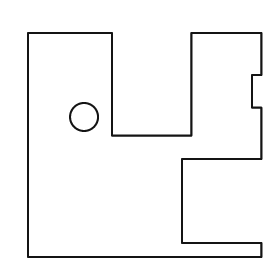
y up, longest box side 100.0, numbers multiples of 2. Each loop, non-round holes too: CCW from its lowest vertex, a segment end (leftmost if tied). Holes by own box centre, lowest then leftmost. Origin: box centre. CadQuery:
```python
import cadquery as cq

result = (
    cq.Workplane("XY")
    .moveTo(-50.0, -48.0)
    .lineTo(50.0, -48.0)
    .lineTo(50.0, -42.0)
    .lineTo(16.0, -42.0)
    .lineTo(16.0, -6.0)
    .lineTo(50.0, -6.0)
    .lineTo(50.0, 16.0)
    .lineTo(46.0, 16.0)
    .lineTo(46.0, 30.0)
    .lineTo(50.0, 30.0)
    .lineTo(50.0, 48.0)
    .lineTo(20.0, 48.0)
    .lineTo(20.0, 4.0)
    .lineTo(-14.0, 4.0)
    .lineTo(-14.0, 48.0)
    .lineTo(-50.0, 48.0)
    .close()
    .moveTo(-26.0, 12.0)
    .circle(6.0)
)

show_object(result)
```